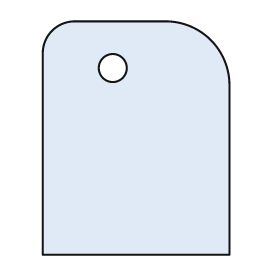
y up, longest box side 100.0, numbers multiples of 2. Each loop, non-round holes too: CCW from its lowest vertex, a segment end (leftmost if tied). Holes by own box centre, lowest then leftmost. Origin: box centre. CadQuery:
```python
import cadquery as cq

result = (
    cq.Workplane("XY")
    .moveTo(-40.0, -50.0)
    .lineTo(40.0, -50.0)
    .lineTo(40.0, 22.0)
    .threePointArc((32.0, 42.0), (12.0, 50.0))
    .lineTo(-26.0, 50.0)
    .threePointArc((-36.0, 46.0), (-40.0, 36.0))
    .close()
    .moveTo(-10.0, 30.0)
    .circle(6.0)
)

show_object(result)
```